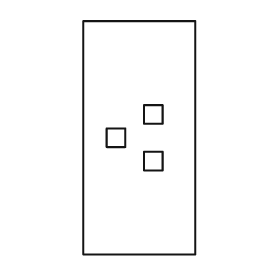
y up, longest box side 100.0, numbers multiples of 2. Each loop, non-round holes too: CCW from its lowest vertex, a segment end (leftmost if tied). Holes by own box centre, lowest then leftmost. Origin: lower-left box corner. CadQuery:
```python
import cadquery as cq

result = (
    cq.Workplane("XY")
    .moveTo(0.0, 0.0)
    .lineTo(48.0, 0.0)
    .lineTo(48.0, 100.0)
    .lineTo(0.0, 100.0)
    .close()
    .moveTo(26.0, 36.0)
    .lineTo(34.0, 36.0)
    .lineTo(34.0, 44.0)
    .lineTo(26.0, 44.0)
    .close()
    .moveTo(10.0, 46.0)
    .lineTo(18.0, 46.0)
    .lineTo(18.0, 54.0)
    .lineTo(10.0, 54.0)
    .close()
    .moveTo(26.0, 56.0)
    .lineTo(34.0, 56.0)
    .lineTo(34.0, 64.0)
    .lineTo(26.0, 64.0)
    .close()
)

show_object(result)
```